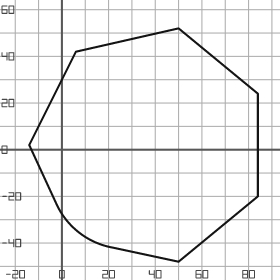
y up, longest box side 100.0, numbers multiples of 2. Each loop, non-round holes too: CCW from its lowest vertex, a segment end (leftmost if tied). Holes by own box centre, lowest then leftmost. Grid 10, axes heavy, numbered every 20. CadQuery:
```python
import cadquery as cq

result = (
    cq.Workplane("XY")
    .moveTo(50.0, -48.0)
    .lineTo(84.0, -20.0)
    .lineTo(84.0, 24.0)
    .lineTo(50.0, 52.0)
    .lineTo(6.0, 42.0)
    .lineTo(-14.0, 2.0)
    .lineTo(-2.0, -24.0)
    .threePointArc((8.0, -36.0), (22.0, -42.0))
    .close()
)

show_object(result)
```